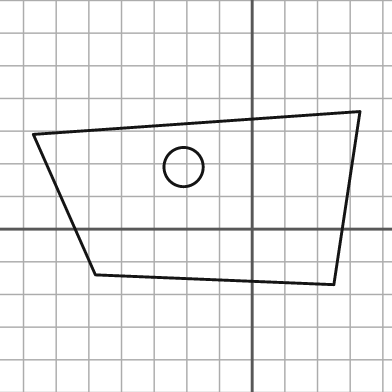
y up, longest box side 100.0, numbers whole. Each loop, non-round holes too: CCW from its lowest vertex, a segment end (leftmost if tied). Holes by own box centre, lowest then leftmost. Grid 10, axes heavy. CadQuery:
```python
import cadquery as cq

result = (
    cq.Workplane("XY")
    .moveTo(25.0, -17.0)
    .lineTo(33.0, 36.0)
    .lineTo(-67.0, 29.0)
    .lineTo(-48.0, -14.0)
    .close()
    .moveTo(-21.0, 19.0)
    .circle(6.0)
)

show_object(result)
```